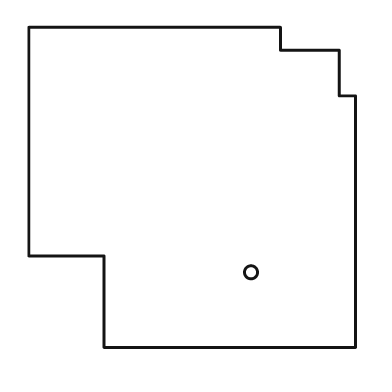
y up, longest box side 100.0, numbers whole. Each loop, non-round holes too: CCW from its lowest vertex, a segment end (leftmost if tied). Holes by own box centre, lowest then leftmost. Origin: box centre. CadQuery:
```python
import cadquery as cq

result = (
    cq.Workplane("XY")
    .moveTo(-27.0, -49.0)
    .lineTo(50.0, -49.0)
    .lineTo(50.0, 28.0)
    .lineTo(45.0, 28.0)
    .lineTo(45.0, 42.0)
    .lineTo(27.0, 42.0)
    .lineTo(27.0, 49.0)
    .lineTo(-50.0, 49.0)
    .lineTo(-50.0, -21.0)
    .lineTo(-27.0, -21.0)
    .close()
    .moveTo(18.0, -26.0)
    .circle(2.0)
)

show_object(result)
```